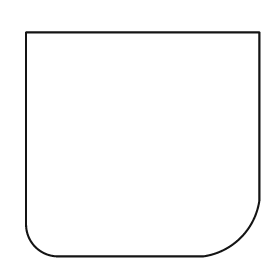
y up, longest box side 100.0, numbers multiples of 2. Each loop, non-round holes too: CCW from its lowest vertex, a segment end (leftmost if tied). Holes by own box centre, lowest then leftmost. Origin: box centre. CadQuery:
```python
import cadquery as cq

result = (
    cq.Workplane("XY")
    .moveTo(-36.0, -48.0)
    .lineTo(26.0, -48.0)
    .threePointArc((42.0, -40.0), (50.0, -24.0))
    .lineTo(50.0, 48.0)
    .lineTo(-50.0, 48.0)
    .lineTo(-50.0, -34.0)
    .threePointArc((-46.0, -44.0), (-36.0, -48.0))
    .close()
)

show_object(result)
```